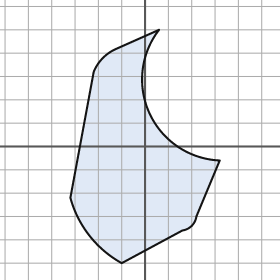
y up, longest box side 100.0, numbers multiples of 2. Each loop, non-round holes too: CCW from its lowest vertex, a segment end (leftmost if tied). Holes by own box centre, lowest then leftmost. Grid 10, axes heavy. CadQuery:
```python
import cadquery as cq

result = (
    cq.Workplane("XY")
    .moveTo(-10.0, -50.0)
    .lineTo(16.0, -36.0)
    .threePointArc((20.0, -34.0), (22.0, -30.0))
    .lineTo(32.0, -6.0)
    .threePointArc((2.0, 14.0), (6.0, 50.0))
    .lineTo(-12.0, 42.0)
    .threePointArc((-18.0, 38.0), (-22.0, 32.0))
    .lineTo(-32.0, -22.0)
    .threePointArc((-24.0, -38.0), (-10.0, -50.0))
    .close()
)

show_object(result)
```